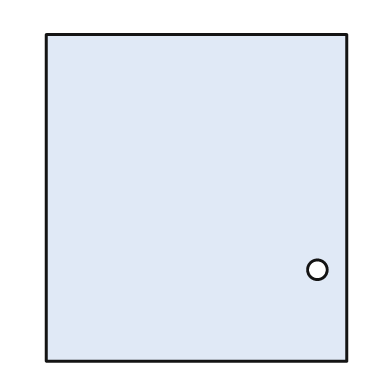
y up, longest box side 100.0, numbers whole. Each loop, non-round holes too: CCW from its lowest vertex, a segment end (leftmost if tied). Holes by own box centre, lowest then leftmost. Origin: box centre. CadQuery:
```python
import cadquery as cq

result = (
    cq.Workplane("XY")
    .moveTo(-46.0, -50.0)
    .lineTo(46.0, -50.0)
    .lineTo(46.0, 50.0)
    .lineTo(-46.0, 50.0)
    .close()
    .moveTo(37.0, -22.0)
    .circle(3.0)
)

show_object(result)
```